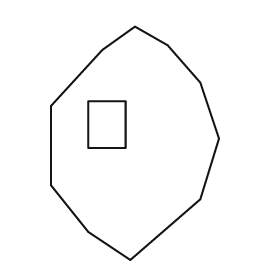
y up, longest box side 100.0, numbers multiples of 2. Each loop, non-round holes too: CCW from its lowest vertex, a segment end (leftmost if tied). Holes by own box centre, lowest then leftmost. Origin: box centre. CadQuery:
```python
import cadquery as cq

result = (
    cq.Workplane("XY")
    .moveTo(-2.0, -50.0)
    .lineTo(28.0, -24.0)
    .lineTo(36.0, 2.0)
    .lineTo(28.0, 26.0)
    .lineTo(14.0, 42.0)
    .lineTo(0.0, 50.0)
    .lineTo(-14.0, 40.0)
    .lineTo(-36.0, 16.0)
    .lineTo(-36.0, -18.0)
    .lineTo(-20.0, -38.0)
    .close()
    .moveTo(-20.0, -2.0)
    .lineTo(-4.0, -2.0)
    .lineTo(-4.0, 18.0)
    .lineTo(-20.0, 18.0)
    .close()
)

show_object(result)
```